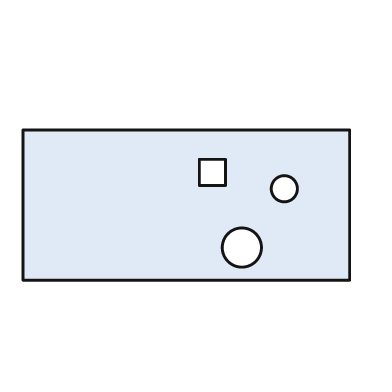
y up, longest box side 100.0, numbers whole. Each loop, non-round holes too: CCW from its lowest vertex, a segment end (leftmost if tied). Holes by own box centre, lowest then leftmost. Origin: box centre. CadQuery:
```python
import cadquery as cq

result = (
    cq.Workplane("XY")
    .moveTo(-50.0, -23.0)
    .lineTo(50.0, -23.0)
    .lineTo(50.0, 23.0)
    .lineTo(-50.0, 23.0)
    .close()
    .moveTo(17.0, -13.0)
    .circle(6.0)
    .moveTo(30.0, 5.0)
    .circle(4.0)
    .moveTo(4.0, 6.0)
    .lineTo(12.0, 6.0)
    .lineTo(12.0, 14.0)
    .lineTo(4.0, 14.0)
    .close()
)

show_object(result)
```